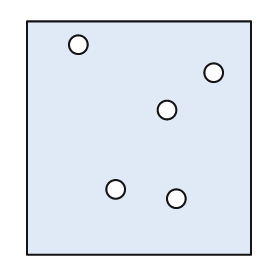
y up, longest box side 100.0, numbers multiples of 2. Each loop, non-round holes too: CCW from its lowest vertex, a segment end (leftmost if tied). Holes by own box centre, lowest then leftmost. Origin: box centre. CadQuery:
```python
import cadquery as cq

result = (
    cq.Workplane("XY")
    .moveTo(-48.0, -50.0)
    .lineTo(48.0, -50.0)
    .lineTo(48.0, 50.0)
    .lineTo(-48.0, 50.0)
    .close()
    .moveTo(16.0, -26.0)
    .circle(4.0)
    .moveTo(-10.0, -22.0)
    .circle(4.0)
    .moveTo(12.0, 12.0)
    .circle(4.0)
    .moveTo(32.0, 28.0)
    .circle(4.0)
    .moveTo(-26.0, 40.0)
    .circle(4.0)
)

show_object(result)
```